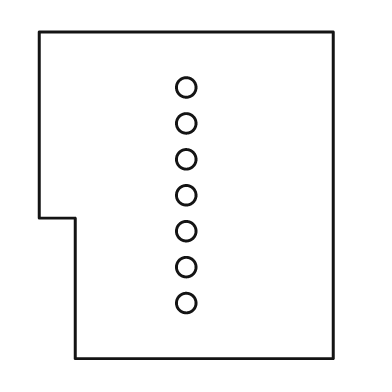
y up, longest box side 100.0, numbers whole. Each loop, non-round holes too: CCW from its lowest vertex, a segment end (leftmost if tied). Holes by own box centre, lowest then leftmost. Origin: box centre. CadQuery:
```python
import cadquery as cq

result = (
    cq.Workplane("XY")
    .moveTo(-34.0, -50.0)
    .lineTo(45.0, -50.0)
    .lineTo(45.0, 50.0)
    .lineTo(-45.0, 50.0)
    .lineTo(-45.0, -7.0)
    .lineTo(-34.0, -7.0)
    .close()
    .moveTo(0.0, -33.0)
    .circle(3.0)
    .moveTo(0.0, -22.0)
    .circle(3.0)
    .moveTo(0.0, -11.0)
    .circle(3.0)
    .moveTo(0.0, 0.0)
    .circle(3.0)
    .moveTo(0.0, 11.0)
    .circle(3.0)
    .moveTo(0.0, 22.0)
    .circle(3.0)
    .moveTo(0.0, 33.0)
    .circle(3.0)
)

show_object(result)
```